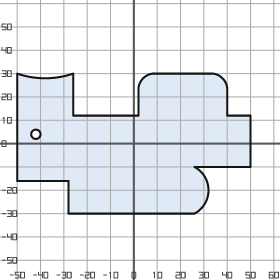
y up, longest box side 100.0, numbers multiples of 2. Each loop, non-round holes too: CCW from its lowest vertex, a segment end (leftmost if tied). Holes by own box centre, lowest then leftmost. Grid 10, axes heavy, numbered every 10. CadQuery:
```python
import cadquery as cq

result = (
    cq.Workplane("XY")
    .moveTo(-28.0, -30.0)
    .lineTo(26.0, -30.0)
    .threePointArc((32.0, -20.0), (26.0, -10.0))
    .lineTo(50.0, -10.0)
    .lineTo(50.0, 12.0)
    .lineTo(40.0, 12.0)
    .lineTo(40.0, 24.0)
    .threePointArc((38.0, 28.0), (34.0, 30.0))
    .lineTo(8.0, 30.0)
    .threePointArc((4.0, 28.0), (2.0, 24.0))
    .lineTo(2.0, 12.0)
    .lineTo(-26.0, 12.0)
    .lineTo(-26.0, 30.0)
    .threePointArc((-38.0, 28.0), (-50.0, 30.0))
    .lineTo(-50.0, -16.0)
    .lineTo(-28.0, -16.0)
    .close()
    .moveTo(-42.0, 4.0)
    .circle(2.0)
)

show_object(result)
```